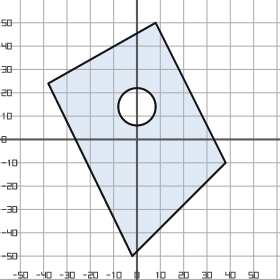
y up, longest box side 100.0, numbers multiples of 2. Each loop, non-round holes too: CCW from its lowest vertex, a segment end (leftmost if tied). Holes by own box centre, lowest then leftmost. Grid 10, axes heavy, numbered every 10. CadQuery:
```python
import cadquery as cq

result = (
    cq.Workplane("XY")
    .moveTo(-2.0, -50.0)
    .lineTo(38.0, -10.0)
    .lineTo(8.0, 50.0)
    .lineTo(-38.0, 24.0)
    .close()
    .moveTo(0.0, 14.0)
    .circle(8.0)
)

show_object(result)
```